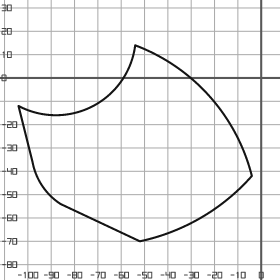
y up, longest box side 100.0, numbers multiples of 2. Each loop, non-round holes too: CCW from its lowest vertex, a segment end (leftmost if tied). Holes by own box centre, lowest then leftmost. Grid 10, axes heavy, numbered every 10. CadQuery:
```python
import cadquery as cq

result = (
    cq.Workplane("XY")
    .moveTo(-52.0, -70.0)
    .threePointArc((-26.0, -60.0), (-4.0, -42.0))
    .threePointArc((-22.0, -8.0), (-54.0, 14.0))
    .threePointArc((-72.0, -12.0), (-104.0, -12.0))
    .lineTo(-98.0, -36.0)
    .threePointArc((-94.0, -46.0), (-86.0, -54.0))
    .close()
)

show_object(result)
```